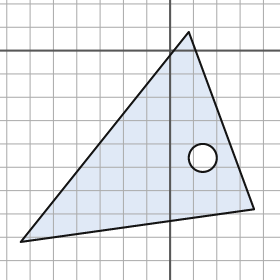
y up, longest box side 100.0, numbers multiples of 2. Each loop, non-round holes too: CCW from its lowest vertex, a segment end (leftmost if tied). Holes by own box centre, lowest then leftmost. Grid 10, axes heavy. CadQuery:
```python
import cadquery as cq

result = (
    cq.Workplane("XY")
    .moveTo(-64.0, -82.0)
    .lineTo(36.0, -68.0)
    .lineTo(8.0, 8.0)
    .close()
    .moveTo(14.0, -46.0)
    .circle(6.0)
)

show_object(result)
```